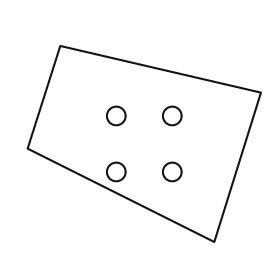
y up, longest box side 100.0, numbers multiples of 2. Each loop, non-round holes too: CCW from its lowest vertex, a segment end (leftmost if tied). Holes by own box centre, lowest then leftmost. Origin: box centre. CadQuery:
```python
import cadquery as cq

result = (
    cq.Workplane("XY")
    .moveTo(30.0, -42.0)
    .lineTo(50.0, 22.0)
    .lineTo(-36.0, 42.0)
    .lineTo(-50.0, -2.0)
    .close()
    .moveTo(-12.0, -12.0)
    .circle(4.0)
    .moveTo(12.0, -12.0)
    .circle(4.0)
    .moveTo(-12.0, 12.0)
    .circle(4.0)
    .moveTo(12.0, 12.0)
    .circle(4.0)
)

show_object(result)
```